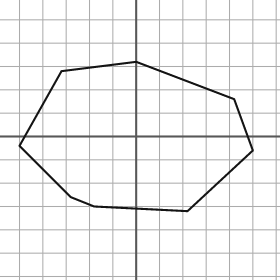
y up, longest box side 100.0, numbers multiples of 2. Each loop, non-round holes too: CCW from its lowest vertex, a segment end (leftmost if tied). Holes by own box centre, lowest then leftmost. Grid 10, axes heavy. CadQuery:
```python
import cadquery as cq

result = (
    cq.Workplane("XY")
    .moveTo(22.0, -32.0)
    .lineTo(50.0, -6.0)
    .lineTo(42.0, 16.0)
    .lineTo(0.0, 32.0)
    .lineTo(-32.0, 28.0)
    .lineTo(-50.0, -4.0)
    .lineTo(-28.0, -26.0)
    .lineTo(-18.0, -30.0)
    .close()
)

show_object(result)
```